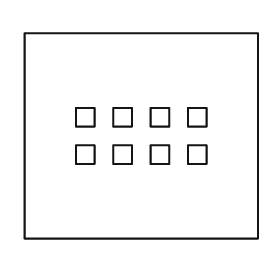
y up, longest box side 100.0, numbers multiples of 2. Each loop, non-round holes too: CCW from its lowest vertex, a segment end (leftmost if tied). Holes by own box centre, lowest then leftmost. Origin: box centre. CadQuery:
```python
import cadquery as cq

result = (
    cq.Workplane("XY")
    .moveTo(-50.0, -44.0)
    .lineTo(50.0, -44.0)
    .lineTo(50.0, 44.0)
    .lineTo(-50.0, 44.0)
    .close()
    .moveTo(-28.0, -12.0)
    .lineTo(-20.0, -12.0)
    .lineTo(-20.0, -4.0)
    .lineTo(-28.0, -4.0)
    .close()
    .moveTo(-12.0, -12.0)
    .lineTo(-4.0, -12.0)
    .lineTo(-4.0, -4.0)
    .lineTo(-12.0, -4.0)
    .close()
    .moveTo(4.0, -12.0)
    .lineTo(12.0, -12.0)
    .lineTo(12.0, -4.0)
    .lineTo(4.0, -4.0)
    .close()
    .moveTo(20.0, -12.0)
    .lineTo(28.0, -12.0)
    .lineTo(28.0, -4.0)
    .lineTo(20.0, -4.0)
    .close()
    .moveTo(-28.0, 4.0)
    .lineTo(-20.0, 4.0)
    .lineTo(-20.0, 12.0)
    .lineTo(-28.0, 12.0)
    .close()
    .moveTo(-12.0, 4.0)
    .lineTo(-4.0, 4.0)
    .lineTo(-4.0, 12.0)
    .lineTo(-12.0, 12.0)
    .close()
    .moveTo(4.0, 4.0)
    .lineTo(12.0, 4.0)
    .lineTo(12.0, 12.0)
    .lineTo(4.0, 12.0)
    .close()
    .moveTo(20.0, 4.0)
    .lineTo(28.0, 4.0)
    .lineTo(28.0, 12.0)
    .lineTo(20.0, 12.0)
    .close()
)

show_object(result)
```